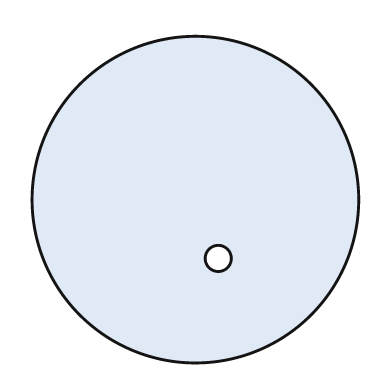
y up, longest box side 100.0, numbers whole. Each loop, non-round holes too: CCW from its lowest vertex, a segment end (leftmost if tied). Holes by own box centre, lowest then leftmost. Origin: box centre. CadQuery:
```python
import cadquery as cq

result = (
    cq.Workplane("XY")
    .moveTo(0.0, 0.0)
    .circle(50.0)
    .moveTo(7.0, -18.0)
    .circle(4.0)
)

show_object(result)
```